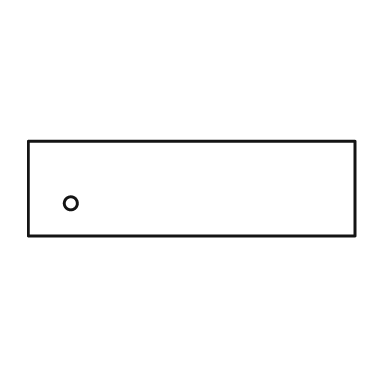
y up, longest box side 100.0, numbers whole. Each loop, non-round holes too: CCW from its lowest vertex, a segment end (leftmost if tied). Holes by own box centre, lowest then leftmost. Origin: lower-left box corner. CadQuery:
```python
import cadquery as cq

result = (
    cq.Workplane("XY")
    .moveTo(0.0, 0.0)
    .lineTo(100.0, 0.0)
    .lineTo(100.0, 29.0)
    .lineTo(0.0, 29.0)
    .close()
    .moveTo(13.0, 10.0)
    .circle(2.0)
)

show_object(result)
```